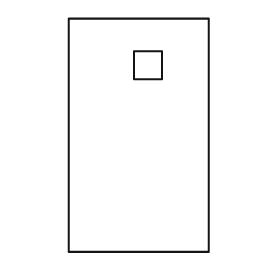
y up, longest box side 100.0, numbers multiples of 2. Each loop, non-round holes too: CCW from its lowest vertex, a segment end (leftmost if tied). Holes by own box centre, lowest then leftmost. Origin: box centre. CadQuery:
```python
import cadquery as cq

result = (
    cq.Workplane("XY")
    .moveTo(-30.0, -50.0)
    .lineTo(30.0, -50.0)
    .lineTo(30.0, 50.0)
    .lineTo(-30.0, 50.0)
    .close()
    .moveTo(-2.0, 24.0)
    .lineTo(10.0, 24.0)
    .lineTo(10.0, 36.0)
    .lineTo(-2.0, 36.0)
    .close()
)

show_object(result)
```